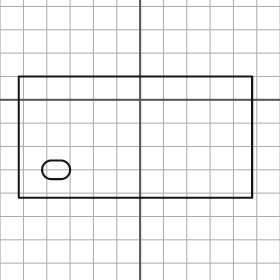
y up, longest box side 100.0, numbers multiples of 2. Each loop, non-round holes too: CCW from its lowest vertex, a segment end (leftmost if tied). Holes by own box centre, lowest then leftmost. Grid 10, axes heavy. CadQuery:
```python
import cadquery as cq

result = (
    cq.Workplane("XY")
    .moveTo(-52.0, -42.0)
    .lineTo(48.0, -42.0)
    .lineTo(48.0, 10.0)
    .lineTo(-52.0, 10.0)
    .close()
    .moveTo(-38.0, -34.0)
    .lineTo(-34.0, -34.0)
    .threePointArc((-30.0, -30.0), (-34.0, -26.0))
    .lineTo(-38.0, -26.0)
    .threePointArc((-42.0, -30.0), (-38.0, -34.0))
    .close()
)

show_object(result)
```